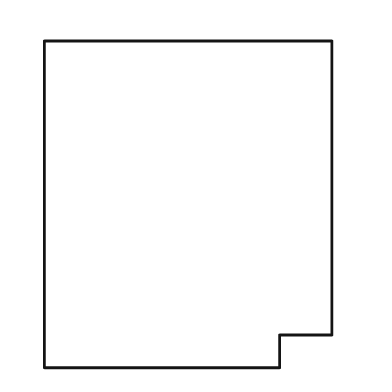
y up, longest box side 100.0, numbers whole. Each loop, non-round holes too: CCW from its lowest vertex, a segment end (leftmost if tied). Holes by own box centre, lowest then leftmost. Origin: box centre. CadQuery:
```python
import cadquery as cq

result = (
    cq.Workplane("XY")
    .moveTo(-44.0, -50.0)
    .lineTo(28.0, -50.0)
    .lineTo(28.0, -40.0)
    .lineTo(44.0, -40.0)
    .lineTo(44.0, 50.0)
    .lineTo(-44.0, 50.0)
    .close()
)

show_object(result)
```